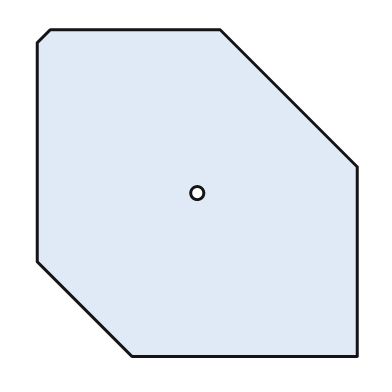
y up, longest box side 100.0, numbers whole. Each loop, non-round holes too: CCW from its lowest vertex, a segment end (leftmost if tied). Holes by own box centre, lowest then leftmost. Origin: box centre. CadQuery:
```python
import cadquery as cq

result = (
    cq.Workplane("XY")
    .moveTo(-20.0, -50.0)
    .lineTo(49.0, -50.0)
    .lineTo(49.0, 8.0)
    .lineTo(7.0, 50.0)
    .lineTo(-45.0, 50.0)
    .lineTo(-49.0, 46.0)
    .lineTo(-49.0, -21.0)
    .close()
    .moveTo(0.0, 0.0)
    .circle(2.0)
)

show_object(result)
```